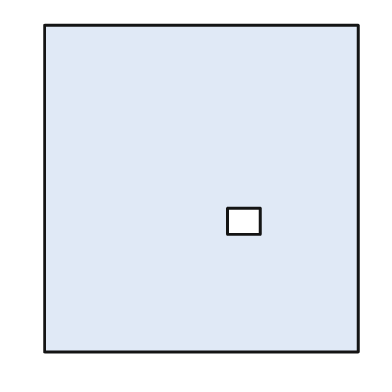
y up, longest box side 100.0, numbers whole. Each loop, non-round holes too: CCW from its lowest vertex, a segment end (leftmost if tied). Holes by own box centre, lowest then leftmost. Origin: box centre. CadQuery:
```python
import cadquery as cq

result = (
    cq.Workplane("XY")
    .moveTo(-48.0, -50.0)
    .lineTo(48.0, -50.0)
    .lineTo(48.0, 50.0)
    .lineTo(-48.0, 50.0)
    .close()
    .moveTo(8.0, -14.0)
    .lineTo(18.0, -14.0)
    .lineTo(18.0, -6.0)
    .lineTo(8.0, -6.0)
    .close()
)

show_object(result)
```